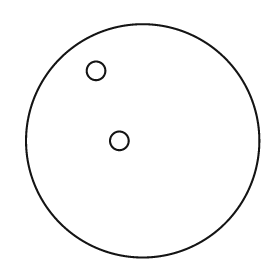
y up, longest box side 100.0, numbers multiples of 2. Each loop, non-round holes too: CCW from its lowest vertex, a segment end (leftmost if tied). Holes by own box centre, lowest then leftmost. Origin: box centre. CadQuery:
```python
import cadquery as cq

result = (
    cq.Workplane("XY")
    .moveTo(0.0, 0.0)
    .circle(50.0)
    .moveTo(-10.0, 0.0)
    .circle(4.0)
    .moveTo(-20.0, 30.0)
    .circle(4.0)
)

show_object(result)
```